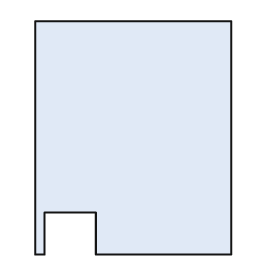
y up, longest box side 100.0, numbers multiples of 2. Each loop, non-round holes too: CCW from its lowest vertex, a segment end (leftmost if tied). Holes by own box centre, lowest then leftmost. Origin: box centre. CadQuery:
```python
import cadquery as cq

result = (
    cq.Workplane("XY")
    .moveTo(-42.0, -50.0)
    .lineTo(-38.0, -50.0)
    .lineTo(-38.0, -32.0)
    .lineTo(-16.0, -32.0)
    .lineTo(-16.0, -50.0)
    .lineTo(42.0, -50.0)
    .lineTo(42.0, 50.0)
    .lineTo(-42.0, 50.0)
    .close()
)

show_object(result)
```